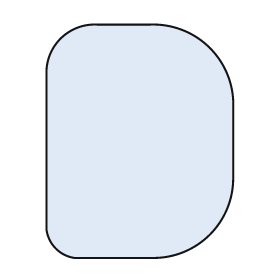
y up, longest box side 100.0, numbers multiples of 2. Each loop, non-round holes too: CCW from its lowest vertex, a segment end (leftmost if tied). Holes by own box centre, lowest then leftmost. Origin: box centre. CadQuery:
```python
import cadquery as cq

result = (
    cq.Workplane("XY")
    .moveTo(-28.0, -50.0)
    .lineTo(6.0, -50.0)
    .threePointArc((30.0, -40.0), (40.0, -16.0))
    .lineTo(40.0, 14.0)
    .threePointArc((30.0, 40.0), (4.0, 50.0))
    .lineTo(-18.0, 50.0)
    .threePointArc((-34.0, 44.0), (-40.0, 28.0))
    .lineTo(-40.0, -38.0)
    .threePointArc((-36.0, -46.0), (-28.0, -50.0))
    .close()
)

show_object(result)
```